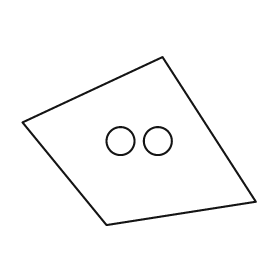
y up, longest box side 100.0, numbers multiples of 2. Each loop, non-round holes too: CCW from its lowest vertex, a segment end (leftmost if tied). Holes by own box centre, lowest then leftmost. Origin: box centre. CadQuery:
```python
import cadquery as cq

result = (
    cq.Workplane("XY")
    .moveTo(-14.0, -36.0)
    .lineTo(50.0, -26.0)
    .lineTo(10.0, 36.0)
    .lineTo(-50.0, 8.0)
    .close()
    .moveTo(-8.0, 0.0)
    .circle(6.0)
    .moveTo(8.0, 0.0)
    .circle(6.0)
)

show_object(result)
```